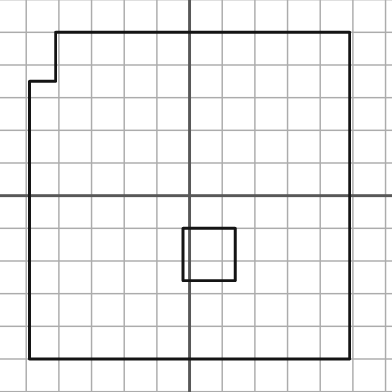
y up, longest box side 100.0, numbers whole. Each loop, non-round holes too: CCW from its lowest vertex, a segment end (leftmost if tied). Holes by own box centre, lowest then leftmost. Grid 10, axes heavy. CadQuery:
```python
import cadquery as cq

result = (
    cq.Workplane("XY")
    .moveTo(-49.0, -50.0)
    .lineTo(49.0, -50.0)
    .lineTo(49.0, 50.0)
    .lineTo(-41.0, 50.0)
    .lineTo(-41.0, 35.0)
    .lineTo(-49.0, 35.0)
    .close()
    .moveTo(-2.0, -26.0)
    .lineTo(14.0, -26.0)
    .lineTo(14.0, -10.0)
    .lineTo(-2.0, -10.0)
    .close()
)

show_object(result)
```